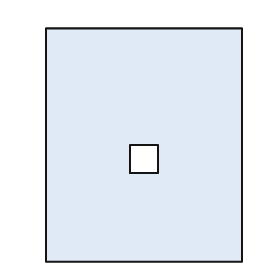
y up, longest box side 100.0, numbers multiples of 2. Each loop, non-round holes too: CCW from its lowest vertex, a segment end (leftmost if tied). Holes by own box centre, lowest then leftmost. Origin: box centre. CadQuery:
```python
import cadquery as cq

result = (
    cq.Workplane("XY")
    .moveTo(-42.0, -50.0)
    .lineTo(42.0, -50.0)
    .lineTo(42.0, 50.0)
    .lineTo(-42.0, 50.0)
    .close()
    .moveTo(-6.0, -12.0)
    .lineTo(6.0, -12.0)
    .lineTo(6.0, 0.0)
    .lineTo(-6.0, 0.0)
    .close()
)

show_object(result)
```